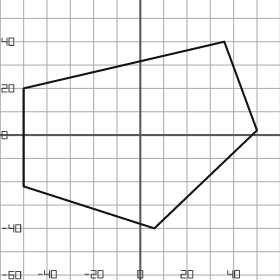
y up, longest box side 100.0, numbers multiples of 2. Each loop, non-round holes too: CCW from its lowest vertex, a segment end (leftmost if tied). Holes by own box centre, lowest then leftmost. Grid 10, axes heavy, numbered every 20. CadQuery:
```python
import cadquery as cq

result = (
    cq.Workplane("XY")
    .moveTo(6.0, -40.0)
    .lineTo(50.0, 2.0)
    .lineTo(36.0, 40.0)
    .lineTo(-50.0, 20.0)
    .lineTo(-50.0, -22.0)
    .close()
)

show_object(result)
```